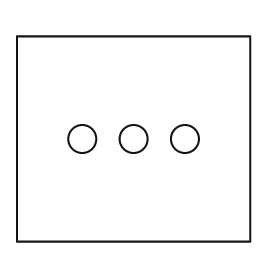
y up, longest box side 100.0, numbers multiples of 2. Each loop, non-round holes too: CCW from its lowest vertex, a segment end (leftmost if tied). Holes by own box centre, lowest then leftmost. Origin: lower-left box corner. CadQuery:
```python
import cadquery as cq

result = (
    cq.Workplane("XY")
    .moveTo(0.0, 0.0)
    .lineTo(100.0, 0.0)
    .lineTo(100.0, 88.0)
    .lineTo(0.0, 88.0)
    .close()
    .moveTo(28.0, 44.0)
    .circle(6.0)
    .moveTo(50.0, 44.0)
    .circle(6.0)
    .moveTo(72.0, 44.0)
    .circle(6.0)
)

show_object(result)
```